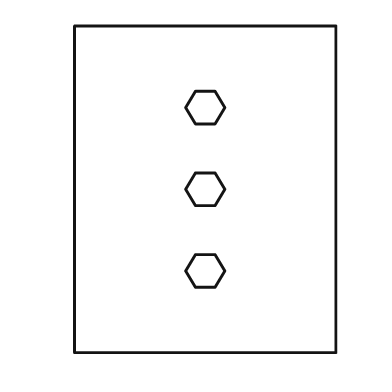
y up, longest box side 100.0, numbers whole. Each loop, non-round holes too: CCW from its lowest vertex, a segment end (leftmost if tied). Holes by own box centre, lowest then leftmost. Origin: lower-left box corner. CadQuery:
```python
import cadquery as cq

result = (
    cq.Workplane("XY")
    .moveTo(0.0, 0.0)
    .lineTo(80.0, 0.0)
    .lineTo(80.0, 100.0)
    .lineTo(0.0, 100.0)
    .close()
    .moveTo(37.0, 20.0)
    .lineTo(43.0, 20.0)
    .lineTo(46.0, 25.0)
    .lineTo(43.0, 30.0)
    .lineTo(37.0, 30.0)
    .lineTo(34.0, 25.0)
    .close()
    .moveTo(37.0, 45.0)
    .lineTo(43.0, 45.0)
    .lineTo(46.0, 50.0)
    .lineTo(43.0, 55.0)
    .lineTo(37.0, 55.0)
    .lineTo(34.0, 50.0)
    .close()
    .moveTo(37.0, 70.0)
    .lineTo(43.0, 70.0)
    .lineTo(46.0, 75.0)
    .lineTo(43.0, 80.0)
    .lineTo(37.0, 80.0)
    .lineTo(34.0, 75.0)
    .close()
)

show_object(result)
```